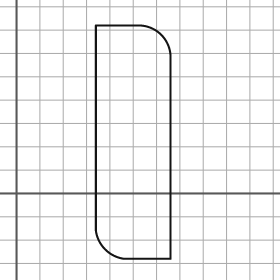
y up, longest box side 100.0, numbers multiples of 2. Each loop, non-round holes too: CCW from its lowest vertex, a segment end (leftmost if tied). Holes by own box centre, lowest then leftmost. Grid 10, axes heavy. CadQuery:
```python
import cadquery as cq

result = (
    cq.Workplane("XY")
    .moveTo(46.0, -28.0)
    .lineTo(66.0, -28.0)
    .lineTo(66.0, 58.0)
    .threePointArc((62.0, 68.0), (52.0, 72.0))
    .lineTo(34.0, 72.0)
    .lineTo(34.0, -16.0)
    .threePointArc((38.0, -24.0), (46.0, -28.0))
    .close()
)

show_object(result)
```